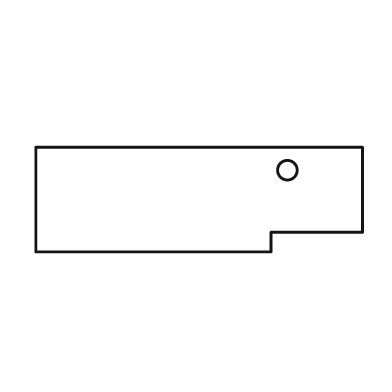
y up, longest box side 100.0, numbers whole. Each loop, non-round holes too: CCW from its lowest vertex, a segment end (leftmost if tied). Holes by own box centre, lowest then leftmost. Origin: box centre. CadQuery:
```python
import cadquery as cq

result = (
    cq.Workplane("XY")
    .moveTo(-50.0, -16.0)
    .lineTo(22.0, -16.0)
    .lineTo(22.0, -10.0)
    .lineTo(50.0, -10.0)
    .lineTo(50.0, 16.0)
    .lineTo(-50.0, 16.0)
    .close()
    .moveTo(27.0, 9.0)
    .circle(3.0)
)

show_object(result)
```